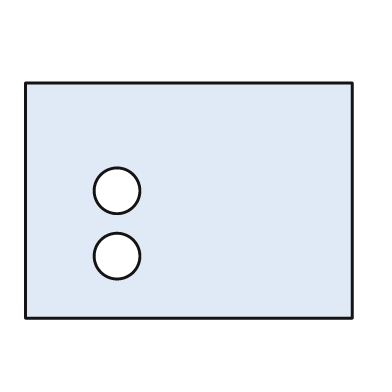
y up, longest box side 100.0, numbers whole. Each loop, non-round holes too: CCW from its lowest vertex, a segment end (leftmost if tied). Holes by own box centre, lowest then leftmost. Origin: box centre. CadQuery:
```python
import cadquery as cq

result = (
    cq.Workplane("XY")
    .moveTo(-50.0, -36.0)
    .lineTo(50.0, -36.0)
    .lineTo(50.0, 36.0)
    .lineTo(-50.0, 36.0)
    .close()
    .moveTo(-22.0, -17.0)
    .circle(7.0)
    .moveTo(-22.0, 3.0)
    .circle(7.0)
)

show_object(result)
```